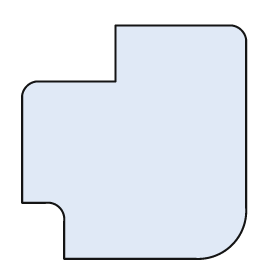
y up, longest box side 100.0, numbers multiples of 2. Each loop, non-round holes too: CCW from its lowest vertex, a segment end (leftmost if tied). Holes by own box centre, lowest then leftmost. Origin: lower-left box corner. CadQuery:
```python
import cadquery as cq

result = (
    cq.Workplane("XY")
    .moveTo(18.0, 0.0)
    .lineTo(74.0, 0.0)
    .threePointArc((90.0, 6.0), (96.0, 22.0))
    .lineTo(96.0, 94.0)
    .threePointArc((94.0, 98.0), (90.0, 100.0))
    .lineTo(40.0, 100.0)
    .lineTo(40.0, 76.0)
    .lineTo(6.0, 76.0)
    .threePointArc((2.0, 74.0), (0.0, 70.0))
    .lineTo(0.0, 24.0)
    .lineTo(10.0, 24.0)
    .threePointArc((16.0, 22.0), (18.0, 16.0))
    .close()
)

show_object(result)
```